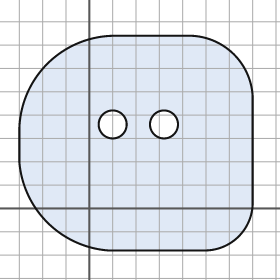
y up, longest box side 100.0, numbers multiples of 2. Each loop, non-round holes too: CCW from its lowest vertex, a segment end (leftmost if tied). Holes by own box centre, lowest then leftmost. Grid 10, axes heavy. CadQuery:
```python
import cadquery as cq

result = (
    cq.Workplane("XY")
    .moveTo(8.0, -18.0)
    .lineTo(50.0, -18.0)
    .threePointArc((64.0, -12.0), (70.0, 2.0))
    .lineTo(70.0, 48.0)
    .threePointArc((62.0, 66.0), (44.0, 74.0))
    .lineTo(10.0, 74.0)
    .threePointArc((-18.0, 62.0), (-30.0, 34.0))
    .lineTo(-30.0, 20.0)
    .threePointArc((-18.0, -6.0), (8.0, -18.0))
    .close()
    .moveTo(10.0, 36.0)
    .circle(6.0)
    .moveTo(32.0, 36.0)
    .circle(6.0)
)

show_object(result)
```